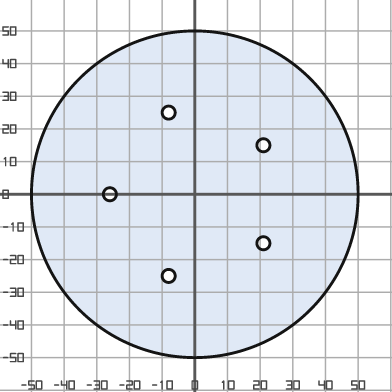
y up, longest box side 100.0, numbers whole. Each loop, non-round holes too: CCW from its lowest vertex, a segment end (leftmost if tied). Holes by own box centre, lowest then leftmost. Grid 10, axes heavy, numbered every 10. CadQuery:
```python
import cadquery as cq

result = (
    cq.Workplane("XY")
    .moveTo(0.0, 0.0)
    .circle(50.0)
    .moveTo(-8.0, -25.0)
    .circle(2.0)
    .moveTo(21.0, -15.0)
    .circle(2.0)
    .moveTo(-26.0, 0.0)
    .circle(2.0)
    .moveTo(21.0, 15.0)
    .circle(2.0)
    .moveTo(-8.0, 25.0)
    .circle(2.0)
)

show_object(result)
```